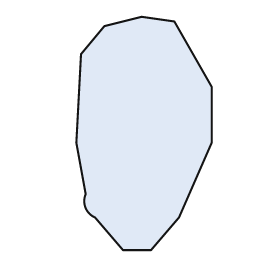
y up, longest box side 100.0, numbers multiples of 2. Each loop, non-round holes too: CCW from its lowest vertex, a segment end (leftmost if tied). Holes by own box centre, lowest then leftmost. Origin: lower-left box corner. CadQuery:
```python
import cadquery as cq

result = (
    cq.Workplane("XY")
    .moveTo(20.0, 0.0)
    .lineTo(32.0, 0.0)
    .lineTo(44.0, 14.0)
    .lineTo(58.0, 46.0)
    .lineTo(58.0, 70.0)
    .lineTo(42.0, 98.0)
    .lineTo(28.0, 100.0)
    .lineTo(12.0, 96.0)
    .lineTo(2.0, 84.0)
    .lineTo(0.0, 46.0)
    .lineTo(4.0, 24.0)
    .threePointArc((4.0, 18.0), (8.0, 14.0))
    .close()
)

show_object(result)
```